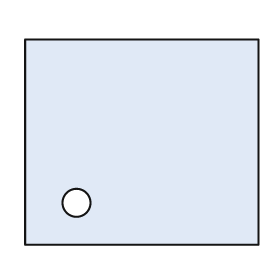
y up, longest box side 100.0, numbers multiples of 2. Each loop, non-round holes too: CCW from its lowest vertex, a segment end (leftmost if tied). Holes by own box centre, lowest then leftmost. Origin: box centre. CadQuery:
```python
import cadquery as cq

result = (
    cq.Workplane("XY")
    .moveTo(-50.0, -44.0)
    .lineTo(50.0, -44.0)
    .lineTo(50.0, 44.0)
    .lineTo(-50.0, 44.0)
    .close()
    .moveTo(-28.0, -26.0)
    .circle(6.0)
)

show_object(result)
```